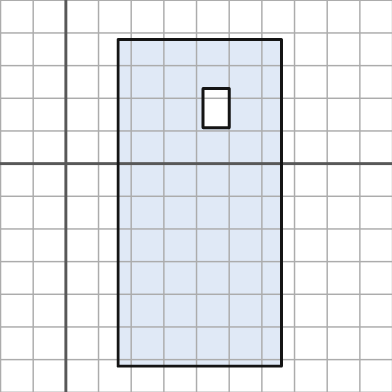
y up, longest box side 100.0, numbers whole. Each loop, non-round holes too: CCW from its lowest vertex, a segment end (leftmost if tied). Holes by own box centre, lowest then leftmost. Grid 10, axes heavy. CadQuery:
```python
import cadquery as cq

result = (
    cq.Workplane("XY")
    .moveTo(16.0, -62.0)
    .lineTo(66.0, -62.0)
    .lineTo(66.0, 38.0)
    .lineTo(16.0, 38.0)
    .close()
    .moveTo(42.0, 11.0)
    .lineTo(50.0, 11.0)
    .lineTo(50.0, 23.0)
    .lineTo(42.0, 23.0)
    .close()
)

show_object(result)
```